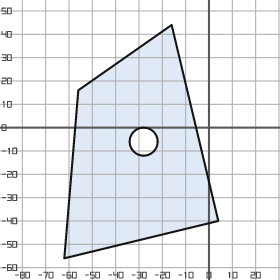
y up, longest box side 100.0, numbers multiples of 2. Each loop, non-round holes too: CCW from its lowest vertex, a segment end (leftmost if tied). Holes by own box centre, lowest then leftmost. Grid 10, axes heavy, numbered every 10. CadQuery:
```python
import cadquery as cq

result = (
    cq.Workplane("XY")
    .moveTo(-62.0, -56.0)
    .lineTo(4.0, -40.0)
    .lineTo(-16.0, 44.0)
    .lineTo(-56.0, 16.0)
    .close()
    .moveTo(-28.0, -6.0)
    .circle(6.0)
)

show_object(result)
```